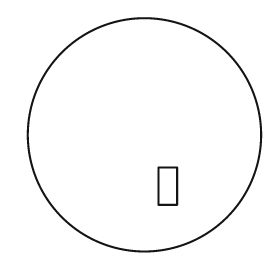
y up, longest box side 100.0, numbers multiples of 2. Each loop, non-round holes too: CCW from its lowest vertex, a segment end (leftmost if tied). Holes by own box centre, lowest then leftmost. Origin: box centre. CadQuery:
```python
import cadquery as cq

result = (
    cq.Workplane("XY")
    .moveTo(0.0, 0.0)
    .circle(50.0)
    .moveTo(6.0, -30.0)
    .lineTo(14.0, -30.0)
    .lineTo(14.0, -14.0)
    .lineTo(6.0, -14.0)
    .close()
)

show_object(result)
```